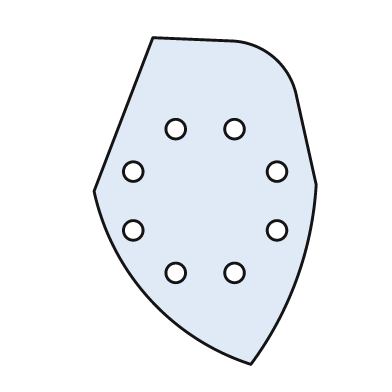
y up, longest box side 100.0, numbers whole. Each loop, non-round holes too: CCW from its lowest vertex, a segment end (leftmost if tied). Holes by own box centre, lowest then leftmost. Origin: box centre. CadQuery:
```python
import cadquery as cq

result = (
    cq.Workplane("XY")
    .moveTo(14.0, -50.0)
    .threePointArc((28.0, -24.0), (34.0, 5.0))
    .lineTo(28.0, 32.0)
    .threePointArc((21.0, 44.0), (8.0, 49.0))
    .lineTo(-16.0, 50.0)
    .lineTo(-34.0, 3.0)
    .threePointArc((-17.0, -30.0), (14.0, -50.0))
    .close()
    .moveTo(-9.0, -22.0)
    .circle(3.0)
    .moveTo(9.0, -22.0)
    .circle(3.0)
    .moveTo(-22.0, -9.0)
    .circle(3.0)
    .moveTo(22.0, -9.0)
    .circle(3.0)
    .moveTo(-22.0, 9.0)
    .circle(3.0)
    .moveTo(22.0, 9.0)
    .circle(3.0)
    .moveTo(-9.0, 22.0)
    .circle(3.0)
    .moveTo(9.0, 22.0)
    .circle(3.0)
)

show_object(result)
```